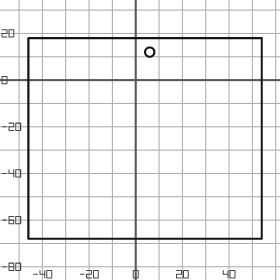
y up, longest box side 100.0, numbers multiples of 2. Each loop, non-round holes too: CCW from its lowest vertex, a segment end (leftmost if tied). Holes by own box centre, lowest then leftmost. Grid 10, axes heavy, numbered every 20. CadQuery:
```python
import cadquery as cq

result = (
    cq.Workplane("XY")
    .moveTo(-46.0, -68.0)
    .lineTo(54.0, -68.0)
    .lineTo(54.0, 18.0)
    .lineTo(-46.0, 18.0)
    .close()
    .moveTo(6.0, 12.0)
    .circle(2.0)
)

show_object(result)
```